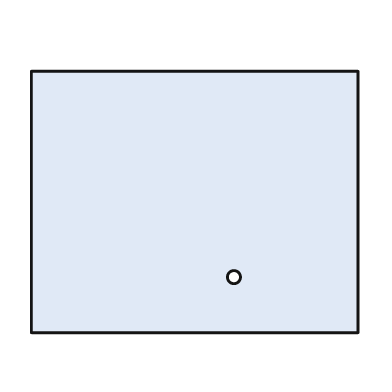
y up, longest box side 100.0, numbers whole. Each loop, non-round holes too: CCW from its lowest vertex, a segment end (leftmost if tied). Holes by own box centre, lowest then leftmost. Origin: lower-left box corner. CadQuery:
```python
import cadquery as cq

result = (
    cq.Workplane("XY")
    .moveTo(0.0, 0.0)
    .lineTo(100.0, 0.0)
    .lineTo(100.0, 80.0)
    .lineTo(0.0, 80.0)
    .close()
    .moveTo(62.0, 17.0)
    .circle(2.0)
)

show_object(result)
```